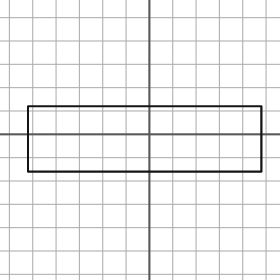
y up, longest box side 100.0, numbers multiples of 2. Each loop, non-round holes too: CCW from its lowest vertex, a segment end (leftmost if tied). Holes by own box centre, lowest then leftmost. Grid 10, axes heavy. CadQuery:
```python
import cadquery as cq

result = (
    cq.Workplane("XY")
    .moveTo(-52.0, -16.0)
    .lineTo(48.0, -16.0)
    .lineTo(48.0, 12.0)
    .lineTo(-52.0, 12.0)
    .close()
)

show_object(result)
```